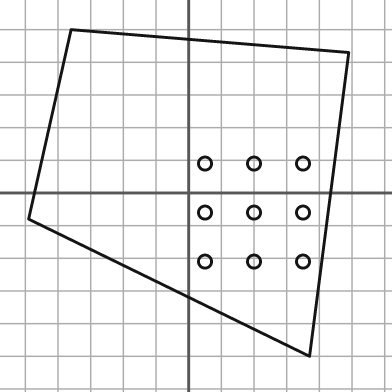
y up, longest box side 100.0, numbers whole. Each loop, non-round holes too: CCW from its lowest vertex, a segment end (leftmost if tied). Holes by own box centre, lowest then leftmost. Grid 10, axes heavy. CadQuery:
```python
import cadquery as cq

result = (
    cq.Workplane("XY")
    .moveTo(37.0, -50.0)
    .lineTo(49.0, 43.0)
    .lineTo(-36.0, 50.0)
    .lineTo(-49.0, -8.0)
    .close()
    .moveTo(5.0, -21.0)
    .circle(2.0)
    .moveTo(20.0, -21.0)
    .circle(2.0)
    .moveTo(35.0, -21.0)
    .circle(2.0)
    .moveTo(5.0, -6.0)
    .circle(2.0)
    .moveTo(20.0, -6.0)
    .circle(2.0)
    .moveTo(35.0, -6.0)
    .circle(2.0)
    .moveTo(5.0, 9.0)
    .circle(2.0)
    .moveTo(20.0, 9.0)
    .circle(2.0)
    .moveTo(35.0, 9.0)
    .circle(2.0)
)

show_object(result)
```